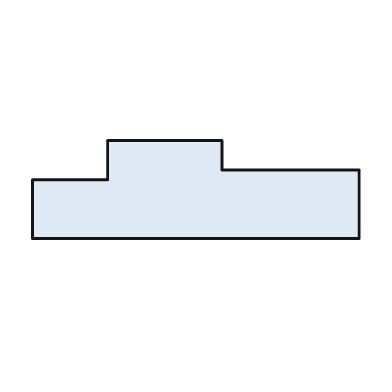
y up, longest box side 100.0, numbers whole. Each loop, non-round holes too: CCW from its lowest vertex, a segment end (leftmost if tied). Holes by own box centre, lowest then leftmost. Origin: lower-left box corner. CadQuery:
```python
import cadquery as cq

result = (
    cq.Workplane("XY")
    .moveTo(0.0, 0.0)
    .lineTo(100.0, 0.0)
    .lineTo(100.0, 21.0)
    .lineTo(58.0, 21.0)
    .lineTo(58.0, 30.0)
    .lineTo(23.0, 30.0)
    .lineTo(23.0, 18.0)
    .lineTo(0.0, 18.0)
    .close()
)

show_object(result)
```